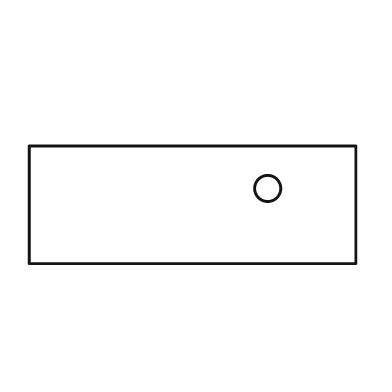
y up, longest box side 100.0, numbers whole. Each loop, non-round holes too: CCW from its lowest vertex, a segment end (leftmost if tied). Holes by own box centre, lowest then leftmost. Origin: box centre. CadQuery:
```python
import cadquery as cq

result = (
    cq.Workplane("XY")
    .moveTo(-50.0, -18.0)
    .lineTo(50.0, -18.0)
    .lineTo(50.0, 18.0)
    .lineTo(-50.0, 18.0)
    .close()
    .moveTo(23.0, 5.0)
    .circle(4.0)
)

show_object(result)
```